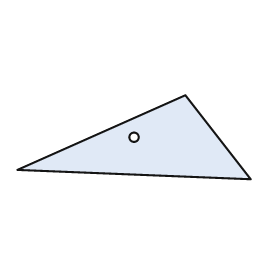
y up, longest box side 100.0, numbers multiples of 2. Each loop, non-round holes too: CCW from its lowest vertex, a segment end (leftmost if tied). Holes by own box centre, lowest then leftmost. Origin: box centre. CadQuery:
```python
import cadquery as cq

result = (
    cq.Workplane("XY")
    .moveTo(50.0, -18.0)
    .lineTo(22.0, 18.0)
    .lineTo(-50.0, -14.0)
    .close()
    .moveTo(0.0, 0.0)
    .circle(2.0)
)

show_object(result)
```